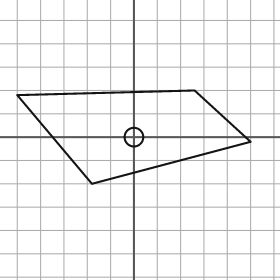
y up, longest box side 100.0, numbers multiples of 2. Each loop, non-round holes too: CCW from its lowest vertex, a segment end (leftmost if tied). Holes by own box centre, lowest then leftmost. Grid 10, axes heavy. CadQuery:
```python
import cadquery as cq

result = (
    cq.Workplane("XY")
    .moveTo(-18.0, -20.0)
    .lineTo(50.0, -2.0)
    .lineTo(26.0, 20.0)
    .lineTo(-50.0, 18.0)
    .close()
    .moveTo(0.0, 0.0)
    .circle(4.0)
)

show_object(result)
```